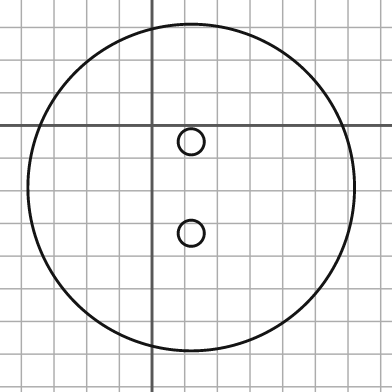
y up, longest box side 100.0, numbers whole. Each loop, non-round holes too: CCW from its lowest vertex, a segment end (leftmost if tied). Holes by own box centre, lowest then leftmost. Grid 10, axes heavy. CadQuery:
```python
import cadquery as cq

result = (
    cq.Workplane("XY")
    .moveTo(12.0, -19.0)
    .circle(50.0)
    .moveTo(12.0, -33.0)
    .circle(4.0)
    .moveTo(12.0, -5.0)
    .circle(4.0)
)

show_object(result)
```